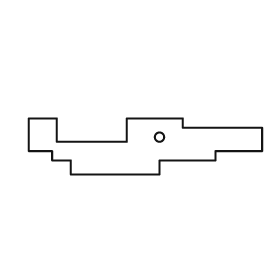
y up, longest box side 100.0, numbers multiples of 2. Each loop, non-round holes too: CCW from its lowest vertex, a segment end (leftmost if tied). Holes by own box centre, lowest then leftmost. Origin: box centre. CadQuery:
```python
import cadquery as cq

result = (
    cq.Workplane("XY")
    .moveTo(-32.0, -12.0)
    .lineTo(6.0, -12.0)
    .lineTo(6.0, -6.0)
    .lineTo(30.0, -6.0)
    .lineTo(30.0, -2.0)
    .lineTo(50.0, -2.0)
    .lineTo(50.0, 8.0)
    .lineTo(16.0, 8.0)
    .lineTo(16.0, 12.0)
    .lineTo(-8.0, 12.0)
    .lineTo(-8.0, 2.0)
    .lineTo(-38.0, 2.0)
    .lineTo(-38.0, 12.0)
    .lineTo(-50.0, 12.0)
    .lineTo(-50.0, -2.0)
    .lineTo(-40.0, -2.0)
    .lineTo(-40.0, -6.0)
    .lineTo(-32.0, -6.0)
    .close()
    .moveTo(6.0, 4.0)
    .circle(2.0)
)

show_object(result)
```